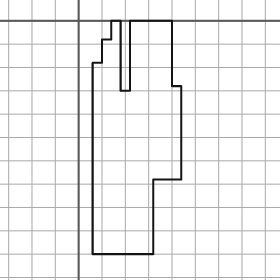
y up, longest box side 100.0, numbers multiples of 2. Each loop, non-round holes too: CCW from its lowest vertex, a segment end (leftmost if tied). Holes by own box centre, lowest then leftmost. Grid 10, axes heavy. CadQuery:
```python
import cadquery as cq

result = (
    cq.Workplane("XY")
    .moveTo(6.0, -100.0)
    .lineTo(32.0, -100.0)
    .lineTo(32.0, -68.0)
    .lineTo(44.0, -68.0)
    .lineTo(44.0, -28.0)
    .lineTo(40.0, -28.0)
    .lineTo(40.0, 0.0)
    .lineTo(22.0, 0.0)
    .lineTo(22.0, -30.0)
    .lineTo(18.0, -30.0)
    .lineTo(18.0, 0.0)
    .lineTo(14.0, 0.0)
    .lineTo(14.0, -8.0)
    .lineTo(10.0, -8.0)
    .lineTo(10.0, -18.0)
    .lineTo(6.0, -18.0)
    .close()
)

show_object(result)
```